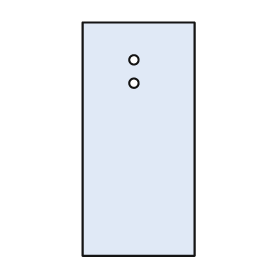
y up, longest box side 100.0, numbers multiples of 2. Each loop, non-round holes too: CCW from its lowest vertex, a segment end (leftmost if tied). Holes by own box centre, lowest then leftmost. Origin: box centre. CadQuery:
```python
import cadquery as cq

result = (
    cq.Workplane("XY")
    .moveTo(-24.0, -50.0)
    .lineTo(24.0, -50.0)
    .lineTo(24.0, 50.0)
    .lineTo(-24.0, 50.0)
    .close()
    .moveTo(-2.0, 24.0)
    .circle(2.0)
    .moveTo(-2.0, 34.0)
    .circle(2.0)
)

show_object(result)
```